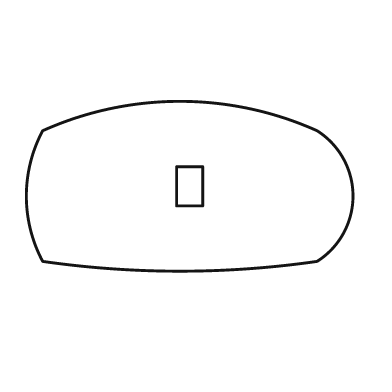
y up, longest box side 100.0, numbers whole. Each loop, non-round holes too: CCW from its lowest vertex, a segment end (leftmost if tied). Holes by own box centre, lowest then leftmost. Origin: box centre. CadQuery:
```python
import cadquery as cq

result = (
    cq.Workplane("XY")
    .moveTo(-45.0, -23.0)
    .threePointArc((-3.0, -26.0), (39.0, -23.0))
    .threePointArc((50.0, -3.0), (39.0, 17.0))
    .threePointArc((-3.0, 26.0), (-45.0, 17.0))
    .threePointArc((-50.0, -3.0), (-45.0, -23.0))
    .close()
    .moveTo(-4.0, -6.0)
    .lineTo(4.0, -6.0)
    .lineTo(4.0, 6.0)
    .lineTo(-4.0, 6.0)
    .close()
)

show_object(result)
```